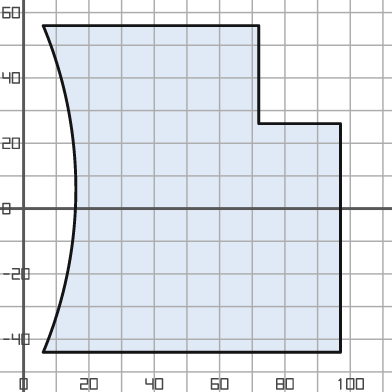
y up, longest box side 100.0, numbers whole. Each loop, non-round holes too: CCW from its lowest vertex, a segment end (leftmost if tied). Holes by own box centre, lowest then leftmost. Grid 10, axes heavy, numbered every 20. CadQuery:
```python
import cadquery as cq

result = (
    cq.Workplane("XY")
    .moveTo(6.0, -44.0)
    .lineTo(97.0, -44.0)
    .lineTo(97.0, 26.0)
    .lineTo(72.0, 26.0)
    .lineTo(72.0, 56.0)
    .lineTo(6.0, 56.0)
    .threePointArc((16.0, 6.0), (6.0, -44.0))
    .close()
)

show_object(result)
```